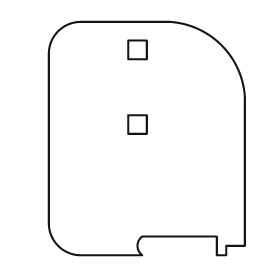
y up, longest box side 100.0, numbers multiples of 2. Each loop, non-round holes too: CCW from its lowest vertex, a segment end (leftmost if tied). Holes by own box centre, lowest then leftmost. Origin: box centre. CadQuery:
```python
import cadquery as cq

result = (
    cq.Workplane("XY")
    .moveTo(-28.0, -50.0)
    .lineTo(-2.0, -50.0)
    .threePointArc((-4.0, -46.0), (-2.0, -42.0))
    .lineTo(30.0, -42.0)
    .lineTo(30.0, -50.0)
    .lineTo(34.0, -50.0)
    .lineTo(34.0, -46.0)
    .lineTo(42.0, -46.0)
    .lineTo(42.0, 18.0)
    .threePointArc((32.0, 40.0), (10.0, 50.0))
    .lineTo(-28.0, 50.0)
    .threePointArc((-38.0, 46.0), (-42.0, 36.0))
    .lineTo(-42.0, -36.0)
    .threePointArc((-38.0, -46.0), (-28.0, -50.0))
    .close()
    .moveTo(-8.0, 2.0)
    .lineTo(0.0, 2.0)
    .lineTo(0.0, 10.0)
    .lineTo(-8.0, 10.0)
    .close()
    .moveTo(-8.0, 34.0)
    .lineTo(0.0, 34.0)
    .lineTo(0.0, 42.0)
    .lineTo(-8.0, 42.0)
    .close()
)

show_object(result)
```